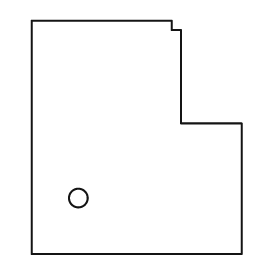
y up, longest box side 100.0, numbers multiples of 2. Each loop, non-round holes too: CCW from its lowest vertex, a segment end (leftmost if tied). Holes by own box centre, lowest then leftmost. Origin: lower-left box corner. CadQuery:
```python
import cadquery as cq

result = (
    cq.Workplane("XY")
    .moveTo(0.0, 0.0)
    .lineTo(90.0, 0.0)
    .lineTo(90.0, 56.0)
    .lineTo(64.0, 56.0)
    .lineTo(64.0, 96.0)
    .lineTo(60.0, 96.0)
    .lineTo(60.0, 100.0)
    .lineTo(0.0, 100.0)
    .close()
    .moveTo(20.0, 24.0)
    .circle(4.0)
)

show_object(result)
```